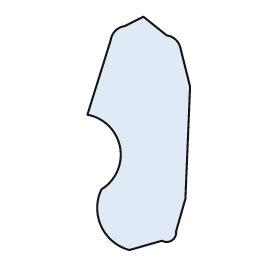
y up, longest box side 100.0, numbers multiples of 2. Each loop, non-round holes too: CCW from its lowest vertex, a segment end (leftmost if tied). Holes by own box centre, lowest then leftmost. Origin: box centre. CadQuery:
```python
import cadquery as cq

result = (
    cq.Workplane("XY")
    .moveTo(-4.0, -50.0)
    .lineTo(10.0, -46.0)
    .threePointArc((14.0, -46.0), (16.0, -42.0))
    .lineTo(20.0, -28.0)
    .lineTo(22.0, 20.0)
    .lineTo(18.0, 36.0)
    .threePointArc((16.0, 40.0), (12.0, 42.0))
    .lineTo(2.0, 50.0)
    .lineTo(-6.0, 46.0)
    .threePointArc((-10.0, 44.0), (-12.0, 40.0))
    .lineTo(-22.0, 8.0)
    .threePointArc((-8.0, -6.0), (-16.0, -24.0))
    .threePointArc((-16.0, -40.0), (-4.0, -50.0))
    .close()
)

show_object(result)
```